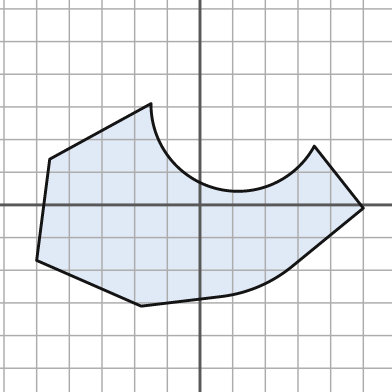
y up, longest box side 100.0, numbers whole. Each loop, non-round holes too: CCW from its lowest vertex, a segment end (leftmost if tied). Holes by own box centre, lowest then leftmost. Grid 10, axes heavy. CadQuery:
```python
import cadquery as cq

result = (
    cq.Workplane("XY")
    .moveTo(-18.0, -31.0)
    .lineTo(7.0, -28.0)
    .threePointArc((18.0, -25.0), (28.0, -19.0))
    .lineTo(50.0, -1.0)
    .lineTo(35.0, 18.0)
    .threePointArc((5.0, 5.0), (-15.0, 31.0))
    .lineTo(-46.0, 14.0)
    .lineTo(-50.0, -17.0)
    .close()
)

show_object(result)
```